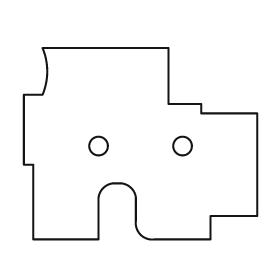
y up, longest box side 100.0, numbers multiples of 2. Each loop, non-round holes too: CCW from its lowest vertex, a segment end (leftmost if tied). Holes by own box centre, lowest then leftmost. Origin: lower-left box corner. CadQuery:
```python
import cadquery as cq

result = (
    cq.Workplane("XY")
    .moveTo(4.0, 0.0)
    .lineTo(32.0, 0.0)
    .lineTo(32.0, 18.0)
    .threePointArc((34.0, 22.0), (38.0, 24.0))
    .lineTo(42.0, 24.0)
    .threePointArc((46.0, 22.0), (48.0, 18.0))
    .lineTo(48.0, 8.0)
    .threePointArc((50.0, 2.0), (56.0, 0.0))
    .lineTo(80.0, 0.0)
    .lineTo(80.0, 10.0)
    .lineTo(100.0, 10.0)
    .lineTo(100.0, 54.0)
    .lineTo(76.0, 54.0)
    .lineTo(76.0, 58.0)
    .lineTo(62.0, 58.0)
    .lineTo(62.0, 82.0)
    .lineTo(8.0, 82.0)
    .threePointArc((10.0, 72.0), (8.0, 62.0))
    .lineTo(0.0, 62.0)
    .lineTo(0.0, 32.0)
    .lineTo(4.0, 32.0)
    .close()
    .moveTo(32.0, 40.0)
    .circle(4.0)
    .moveTo(68.0, 40.0)
    .circle(4.0)
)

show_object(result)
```